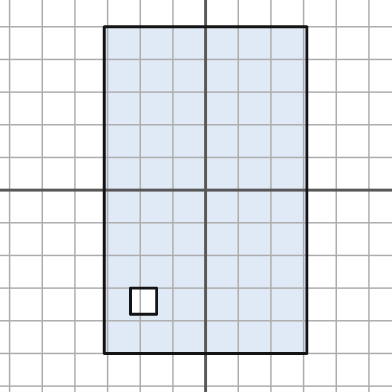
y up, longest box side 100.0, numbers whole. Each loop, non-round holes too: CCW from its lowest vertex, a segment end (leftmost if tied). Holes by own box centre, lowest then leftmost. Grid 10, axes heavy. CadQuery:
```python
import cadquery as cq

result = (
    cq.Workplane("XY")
    .moveTo(-31.0, -50.0)
    .lineTo(31.0, -50.0)
    .lineTo(31.0, 50.0)
    .lineTo(-31.0, 50.0)
    .close()
    .moveTo(-23.0, -38.0)
    .lineTo(-15.0, -38.0)
    .lineTo(-15.0, -30.0)
    .lineTo(-23.0, -30.0)
    .close()
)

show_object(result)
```